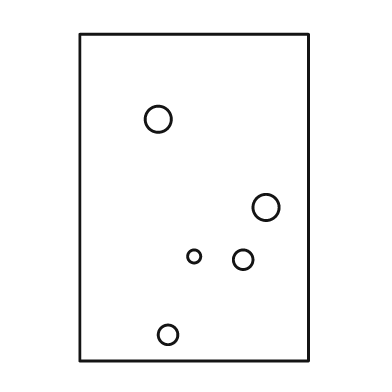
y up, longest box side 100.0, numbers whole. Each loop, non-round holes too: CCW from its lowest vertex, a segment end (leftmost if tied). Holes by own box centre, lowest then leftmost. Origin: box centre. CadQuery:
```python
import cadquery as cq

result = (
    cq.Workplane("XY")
    .moveTo(-35.0, -50.0)
    .lineTo(35.0, -50.0)
    .lineTo(35.0, 50.0)
    .lineTo(-35.0, 50.0)
    .close()
    .moveTo(-8.0, -42.0)
    .circle(3.0)
    .moveTo(15.0, -19.0)
    .circle(3.0)
    .moveTo(0.0, -18.0)
    .circle(2.0)
    .moveTo(22.0, -3.0)
    .circle(4.0)
    .moveTo(-11.0, 24.0)
    .circle(4.0)
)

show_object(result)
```